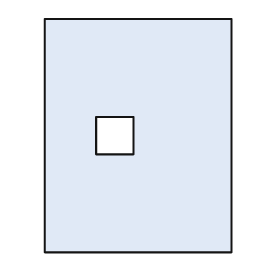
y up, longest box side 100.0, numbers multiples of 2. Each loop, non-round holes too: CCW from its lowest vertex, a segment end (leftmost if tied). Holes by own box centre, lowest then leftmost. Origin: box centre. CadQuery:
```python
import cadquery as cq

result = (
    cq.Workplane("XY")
    .moveTo(-40.0, -50.0)
    .lineTo(40.0, -50.0)
    .lineTo(40.0, 50.0)
    .lineTo(-40.0, 50.0)
    .close()
    .moveTo(-18.0, -8.0)
    .lineTo(-2.0, -8.0)
    .lineTo(-2.0, 8.0)
    .lineTo(-18.0, 8.0)
    .close()
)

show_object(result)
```